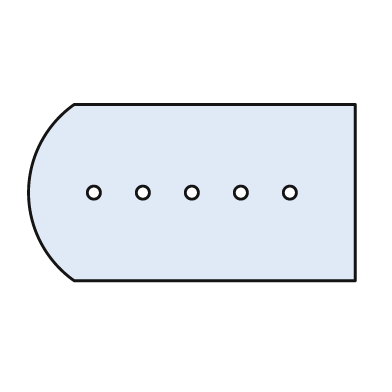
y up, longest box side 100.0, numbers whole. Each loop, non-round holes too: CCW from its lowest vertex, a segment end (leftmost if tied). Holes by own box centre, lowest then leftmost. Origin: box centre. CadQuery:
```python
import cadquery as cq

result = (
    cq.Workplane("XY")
    .moveTo(-36.0, -27.0)
    .lineTo(50.0, -27.0)
    .lineTo(50.0, 27.0)
    .lineTo(-36.0, 27.0)
    .threePointArc((-50.0, 0.0), (-36.0, -27.0))
    .close()
    .moveTo(-30.0, 0.0)
    .circle(2.0)
    .moveTo(-15.0, 0.0)
    .circle(2.0)
    .moveTo(0.0, 0.0)
    .circle(2.0)
    .moveTo(15.0, 0.0)
    .circle(2.0)
    .moveTo(30.0, 0.0)
    .circle(2.0)
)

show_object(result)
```